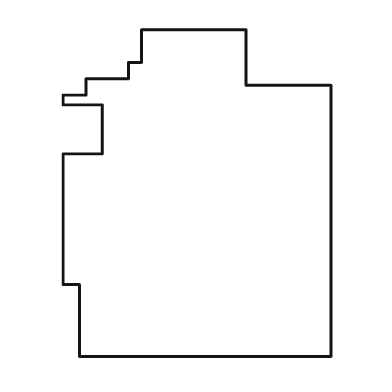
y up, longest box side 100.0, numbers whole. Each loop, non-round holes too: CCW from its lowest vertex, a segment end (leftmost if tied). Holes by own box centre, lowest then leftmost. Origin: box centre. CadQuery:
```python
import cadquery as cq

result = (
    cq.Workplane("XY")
    .moveTo(-36.0, -50.0)
    .lineTo(41.0, -50.0)
    .lineTo(41.0, 33.0)
    .lineTo(15.0, 33.0)
    .lineTo(15.0, 50.0)
    .lineTo(-17.0, 50.0)
    .lineTo(-17.0, 40.0)
    .lineTo(-21.0, 40.0)
    .lineTo(-21.0, 35.0)
    .lineTo(-34.0, 35.0)
    .lineTo(-34.0, 30.0)
    .lineTo(-41.0, 30.0)
    .lineTo(-41.0, 27.0)
    .lineTo(-29.0, 27.0)
    .lineTo(-29.0, 12.0)
    .lineTo(-41.0, 12.0)
    .lineTo(-41.0, -28.0)
    .lineTo(-36.0, -28.0)
    .close()
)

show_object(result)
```